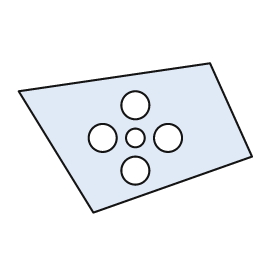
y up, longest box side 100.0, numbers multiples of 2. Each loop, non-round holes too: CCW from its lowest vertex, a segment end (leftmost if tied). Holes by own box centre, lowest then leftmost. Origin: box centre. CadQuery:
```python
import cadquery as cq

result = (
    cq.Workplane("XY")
    .moveTo(-18.0, -32.0)
    .lineTo(50.0, -8.0)
    .lineTo(32.0, 32.0)
    .lineTo(-50.0, 20.0)
    .close()
    .moveTo(0.0, -14.0)
    .circle(6.0)
    .moveTo(-14.0, 0.0)
    .circle(6.0)
    .moveTo(0.0, 0.0)
    .circle(4.0)
    .moveTo(14.0, 0.0)
    .circle(6.0)
    .moveTo(0.0, 14.0)
    .circle(6.0)
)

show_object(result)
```